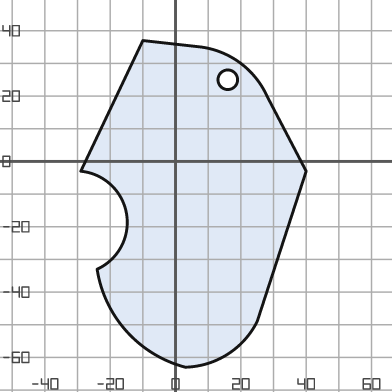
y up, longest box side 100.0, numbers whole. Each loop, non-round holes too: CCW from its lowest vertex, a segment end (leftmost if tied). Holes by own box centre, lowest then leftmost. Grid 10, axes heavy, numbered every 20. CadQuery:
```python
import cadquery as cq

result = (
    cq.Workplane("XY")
    .moveTo(3.0, -63.0)
    .threePointArc((16.0, -59.0), (25.0, -49.0))
    .lineTo(40.0, -3.0)
    .lineTo(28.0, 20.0)
    .threePointArc((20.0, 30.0), (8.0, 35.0))
    .lineTo(-10.0, 37.0)
    .lineTo(-29.0, -3.0)
    .threePointArc((-15.0, -16.0), (-24.0, -33.0))
    .threePointArc((-15.0, -52.0), (3.0, -63.0))
    .close()
    .moveTo(16.0, 25.0)
    .circle(3.0)
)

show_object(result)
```